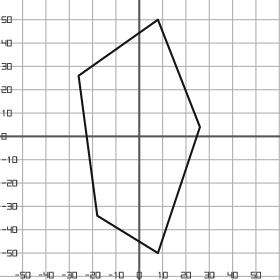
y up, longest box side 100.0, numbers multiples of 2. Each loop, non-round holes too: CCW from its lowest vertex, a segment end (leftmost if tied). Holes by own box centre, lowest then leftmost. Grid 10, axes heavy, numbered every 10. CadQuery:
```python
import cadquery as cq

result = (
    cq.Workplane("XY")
    .moveTo(8.0, -50.0)
    .lineTo(26.0, 4.0)
    .lineTo(8.0, 50.0)
    .lineTo(-26.0, 26.0)
    .lineTo(-18.0, -34.0)
    .close()
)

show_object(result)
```